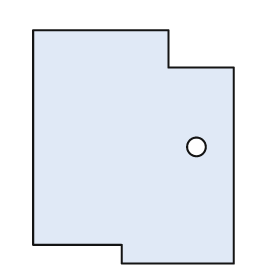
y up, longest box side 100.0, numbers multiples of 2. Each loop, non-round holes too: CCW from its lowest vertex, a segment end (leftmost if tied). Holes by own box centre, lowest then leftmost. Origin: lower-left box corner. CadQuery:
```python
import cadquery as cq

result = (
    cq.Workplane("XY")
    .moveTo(38.0, 0.0)
    .lineTo(86.0, 0.0)
    .lineTo(86.0, 84.0)
    .lineTo(58.0, 84.0)
    .lineTo(58.0, 100.0)
    .lineTo(0.0, 100.0)
    .lineTo(0.0, 8.0)
    .lineTo(38.0, 8.0)
    .close()
    .moveTo(70.0, 50.0)
    .circle(4.0)
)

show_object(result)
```